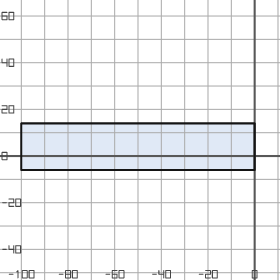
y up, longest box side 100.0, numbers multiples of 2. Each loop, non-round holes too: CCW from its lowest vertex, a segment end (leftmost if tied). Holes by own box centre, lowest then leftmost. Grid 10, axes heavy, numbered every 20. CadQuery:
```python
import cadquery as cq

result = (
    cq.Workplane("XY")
    .moveTo(-100.0, -6.0)
    .lineTo(0.0, -6.0)
    .lineTo(0.0, 14.0)
    .lineTo(-100.0, 14.0)
    .close()
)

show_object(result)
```